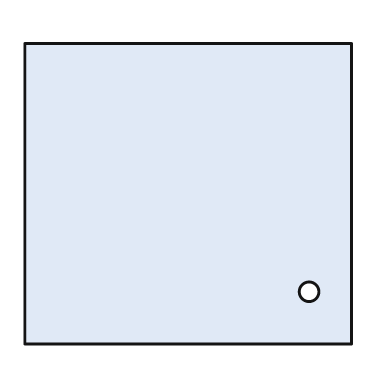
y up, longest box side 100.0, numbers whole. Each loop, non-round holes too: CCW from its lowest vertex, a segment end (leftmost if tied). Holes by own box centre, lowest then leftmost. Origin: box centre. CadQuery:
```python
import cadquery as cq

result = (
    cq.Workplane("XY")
    .moveTo(-50.0, -46.0)
    .lineTo(50.0, -46.0)
    .lineTo(50.0, 46.0)
    .lineTo(-50.0, 46.0)
    .close()
    .moveTo(37.0, -30.0)
    .circle(3.0)
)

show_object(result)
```